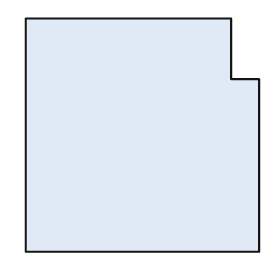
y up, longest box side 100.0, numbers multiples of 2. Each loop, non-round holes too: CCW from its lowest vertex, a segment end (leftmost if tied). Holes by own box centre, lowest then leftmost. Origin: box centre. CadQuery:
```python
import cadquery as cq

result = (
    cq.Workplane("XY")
    .moveTo(-50.0, -50.0)
    .lineTo(50.0, -50.0)
    .lineTo(50.0, 24.0)
    .lineTo(38.0, 24.0)
    .lineTo(38.0, 50.0)
    .lineTo(-50.0, 50.0)
    .close()
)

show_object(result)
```